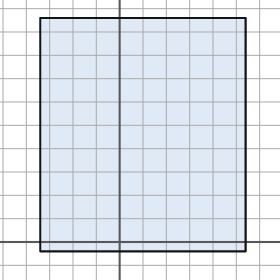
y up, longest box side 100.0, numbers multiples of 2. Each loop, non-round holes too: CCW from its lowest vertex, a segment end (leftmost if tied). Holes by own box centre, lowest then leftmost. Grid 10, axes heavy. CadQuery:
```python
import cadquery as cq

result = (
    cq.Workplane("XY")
    .moveTo(-34.0, -4.0)
    .lineTo(54.0, -4.0)
    .lineTo(54.0, 96.0)
    .lineTo(-34.0, 96.0)
    .close()
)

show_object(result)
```